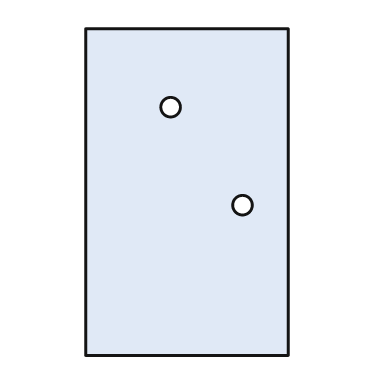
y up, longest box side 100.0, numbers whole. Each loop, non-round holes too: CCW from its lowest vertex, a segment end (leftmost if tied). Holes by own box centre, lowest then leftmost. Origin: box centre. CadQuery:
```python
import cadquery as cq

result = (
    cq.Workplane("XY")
    .moveTo(-31.0, -50.0)
    .lineTo(31.0, -50.0)
    .lineTo(31.0, 50.0)
    .lineTo(-31.0, 50.0)
    .close()
    .moveTo(17.0, -4.0)
    .circle(3.0)
    .moveTo(-5.0, 26.0)
    .circle(3.0)
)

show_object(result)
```